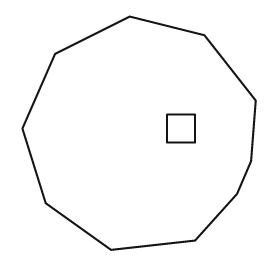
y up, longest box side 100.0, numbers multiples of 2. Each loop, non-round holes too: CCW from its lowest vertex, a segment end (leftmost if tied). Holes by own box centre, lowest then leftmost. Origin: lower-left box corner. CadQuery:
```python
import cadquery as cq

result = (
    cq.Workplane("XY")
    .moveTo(38.0, 0.0)
    .lineTo(74.0, 4.0)
    .lineTo(92.0, 24.0)
    .lineTo(98.0, 38.0)
    .lineTo(100.0, 64.0)
    .lineTo(78.0, 92.0)
    .lineTo(46.0, 100.0)
    .lineTo(14.0, 84.0)
    .lineTo(0.0, 52.0)
    .lineTo(10.0, 20.0)
    .close()
    .moveTo(62.0, 46.0)
    .lineTo(74.0, 46.0)
    .lineTo(74.0, 58.0)
    .lineTo(62.0, 58.0)
    .close()
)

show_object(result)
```